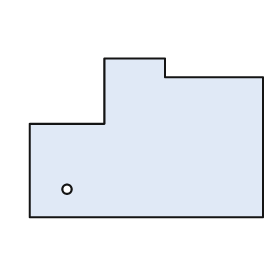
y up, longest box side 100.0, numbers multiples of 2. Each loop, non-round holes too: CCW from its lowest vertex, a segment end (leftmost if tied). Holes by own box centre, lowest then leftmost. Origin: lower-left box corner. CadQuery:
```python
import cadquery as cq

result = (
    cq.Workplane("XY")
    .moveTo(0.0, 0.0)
    .lineTo(100.0, 0.0)
    .lineTo(100.0, 60.0)
    .lineTo(58.0, 60.0)
    .lineTo(58.0, 68.0)
    .lineTo(32.0, 68.0)
    .lineTo(32.0, 40.0)
    .lineTo(0.0, 40.0)
    .close()
    .moveTo(16.0, 12.0)
    .circle(2.0)
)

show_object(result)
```